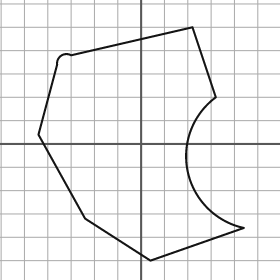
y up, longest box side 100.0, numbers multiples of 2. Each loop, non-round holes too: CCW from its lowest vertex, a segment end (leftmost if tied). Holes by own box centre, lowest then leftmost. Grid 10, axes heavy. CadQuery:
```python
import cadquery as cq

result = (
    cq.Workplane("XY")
    .moveTo(4.0, -50.0)
    .lineTo(44.0, -36.0)
    .threePointArc((20.0, -12.0), (32.0, 20.0))
    .lineTo(22.0, 50.0)
    .lineTo(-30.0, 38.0)
    .threePointArc((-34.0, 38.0), (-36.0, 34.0))
    .lineTo(-44.0, 4.0)
    .lineTo(-24.0, -32.0)
    .close()
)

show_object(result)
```